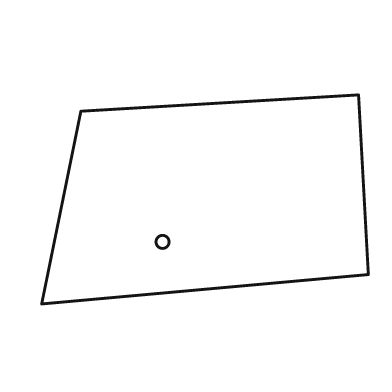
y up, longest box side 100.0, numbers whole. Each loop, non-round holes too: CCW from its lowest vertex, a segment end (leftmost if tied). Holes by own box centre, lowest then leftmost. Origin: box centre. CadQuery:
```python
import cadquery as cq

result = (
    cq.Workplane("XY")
    .moveTo(-50.0, -32.0)
    .lineTo(50.0, -23.0)
    .lineTo(47.0, 32.0)
    .lineTo(-38.0, 27.0)
    .close()
    .moveTo(-13.0, -13.0)
    .circle(2.0)
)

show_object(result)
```